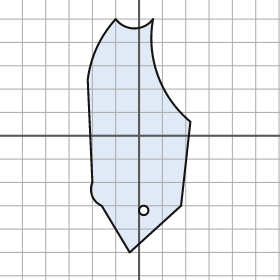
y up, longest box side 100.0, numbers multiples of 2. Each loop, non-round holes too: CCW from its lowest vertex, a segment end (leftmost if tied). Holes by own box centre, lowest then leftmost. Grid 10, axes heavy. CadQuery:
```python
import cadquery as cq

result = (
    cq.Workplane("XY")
    .moveTo(-4.0, -50.0)
    .lineTo(18.0, -30.0)
    .lineTo(22.0, 6.0)
    .threePointArc((8.0, 26.0), (6.0, 50.0))
    .threePointArc((-2.0, 46.0), (-10.0, 50.0))
    .threePointArc((-18.0, 38.0), (-22.0, 24.0))
    .lineTo(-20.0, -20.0)
    .threePointArc((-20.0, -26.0), (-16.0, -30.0))
    .close()
    .moveTo(2.0, -32.0)
    .circle(2.0)
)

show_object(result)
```